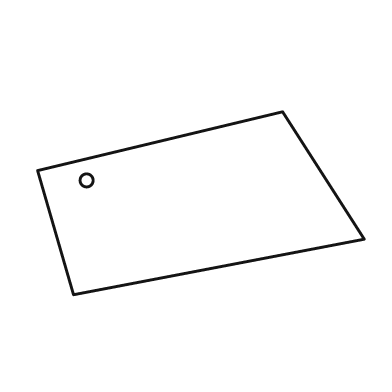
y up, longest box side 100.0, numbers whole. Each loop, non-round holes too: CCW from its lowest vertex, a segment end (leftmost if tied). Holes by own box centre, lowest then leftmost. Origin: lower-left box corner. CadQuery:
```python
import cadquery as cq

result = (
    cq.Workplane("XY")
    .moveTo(11.0, 0.0)
    .lineTo(100.0, 17.0)
    .lineTo(75.0, 56.0)
    .lineTo(0.0, 38.0)
    .close()
    .moveTo(15.0, 35.0)
    .circle(2.0)
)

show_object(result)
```